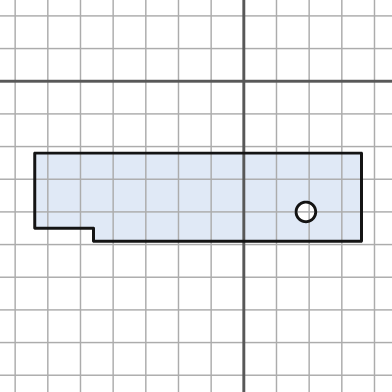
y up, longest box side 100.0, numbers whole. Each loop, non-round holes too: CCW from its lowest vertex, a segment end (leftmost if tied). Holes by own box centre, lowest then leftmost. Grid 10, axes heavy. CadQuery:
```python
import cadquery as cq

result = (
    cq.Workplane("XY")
    .moveTo(-46.0, -49.0)
    .lineTo(36.0, -49.0)
    .lineTo(36.0, -22.0)
    .lineTo(-64.0, -22.0)
    .lineTo(-64.0, -45.0)
    .lineTo(-46.0, -45.0)
    .close()
    .moveTo(19.0, -40.0)
    .circle(3.0)
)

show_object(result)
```